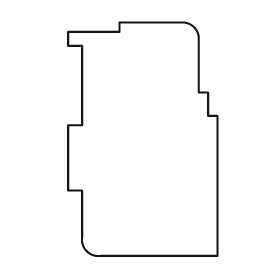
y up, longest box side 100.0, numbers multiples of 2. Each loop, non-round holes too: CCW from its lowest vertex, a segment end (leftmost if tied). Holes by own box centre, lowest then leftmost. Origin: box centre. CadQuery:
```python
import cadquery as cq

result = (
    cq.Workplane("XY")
    .moveTo(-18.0, -50.0)
    .lineTo(32.0, -50.0)
    .lineTo(32.0, 10.0)
    .lineTo(28.0, 10.0)
    .lineTo(28.0, 20.0)
    .lineTo(24.0, 20.0)
    .lineTo(24.0, 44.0)
    .threePointArc((22.0, 48.0), (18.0, 50.0))
    .lineTo(-10.0, 50.0)
    .lineTo(-10.0, 46.0)
    .lineTo(-32.0, 46.0)
    .lineTo(-32.0, 40.0)
    .lineTo(-26.0, 40.0)
    .lineTo(-26.0, 6.0)
    .lineTo(-32.0, 6.0)
    .lineTo(-32.0, -22.0)
    .lineTo(-26.0, -22.0)
    .lineTo(-26.0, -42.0)
    .threePointArc((-24.0, -48.0), (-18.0, -50.0))
    .close()
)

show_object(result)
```